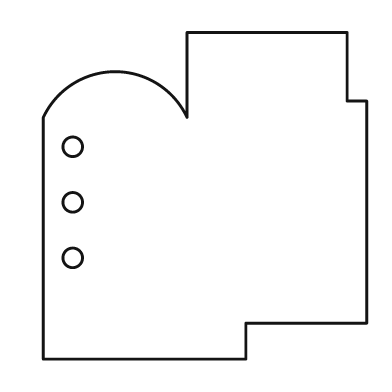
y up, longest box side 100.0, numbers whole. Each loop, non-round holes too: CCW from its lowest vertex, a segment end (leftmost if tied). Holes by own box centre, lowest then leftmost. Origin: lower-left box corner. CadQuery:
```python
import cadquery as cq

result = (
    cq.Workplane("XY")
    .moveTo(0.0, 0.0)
    .lineTo(62.0, 0.0)
    .lineTo(62.0, 11.0)
    .lineTo(99.0, 11.0)
    .lineTo(99.0, 79.0)
    .lineTo(93.0, 79.0)
    .lineTo(93.0, 100.0)
    .lineTo(44.0, 100.0)
    .lineTo(44.0, 74.0)
    .threePointArc((22.0, 88.0), (0.0, 74.0))
    .close()
    .moveTo(9.0, 31.0)
    .circle(3.0)
    .moveTo(9.0, 48.0)
    .circle(3.0)
    .moveTo(9.0, 65.0)
    .circle(3.0)
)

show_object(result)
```